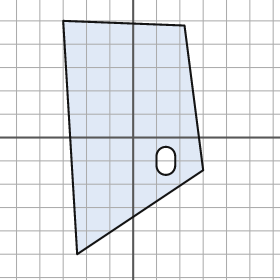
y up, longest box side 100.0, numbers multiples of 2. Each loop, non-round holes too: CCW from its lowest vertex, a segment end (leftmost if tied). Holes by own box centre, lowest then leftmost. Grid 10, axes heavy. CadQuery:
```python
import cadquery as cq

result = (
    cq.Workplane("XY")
    .moveTo(-24.0, -50.0)
    .lineTo(30.0, -14.0)
    .lineTo(22.0, 48.0)
    .lineTo(-30.0, 50.0)
    .close()
    .moveTo(10.0, -12.0)
    .threePointArc((14.0, -16.0), (18.0, -12.0))
    .lineTo(18.0, -8.0)
    .threePointArc((14.0, -4.0), (10.0, -8.0))
    .close()
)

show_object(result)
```